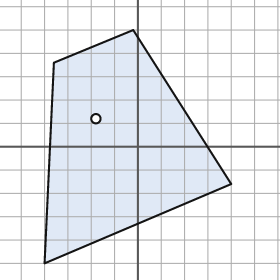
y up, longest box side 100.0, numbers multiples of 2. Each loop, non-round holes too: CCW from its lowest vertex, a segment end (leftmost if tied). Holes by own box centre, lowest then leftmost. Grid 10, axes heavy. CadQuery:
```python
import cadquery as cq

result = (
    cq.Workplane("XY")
    .moveTo(-40.0, -50.0)
    .lineTo(40.0, -16.0)
    .lineTo(-2.0, 50.0)
    .lineTo(-36.0, 36.0)
    .close()
    .moveTo(-18.0, 12.0)
    .circle(2.0)
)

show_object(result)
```